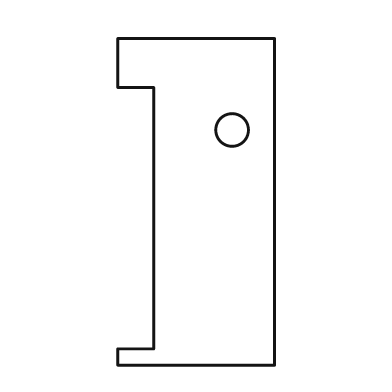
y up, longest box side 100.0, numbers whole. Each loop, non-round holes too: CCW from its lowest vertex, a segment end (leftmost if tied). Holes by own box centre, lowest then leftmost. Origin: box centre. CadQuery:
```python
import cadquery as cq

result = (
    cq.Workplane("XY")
    .moveTo(-24.0, -50.0)
    .lineTo(24.0, -50.0)
    .lineTo(24.0, 50.0)
    .lineTo(-24.0, 50.0)
    .lineTo(-24.0, 35.0)
    .lineTo(-13.0, 35.0)
    .lineTo(-13.0, -45.0)
    .lineTo(-24.0, -45.0)
    .close()
    .moveTo(11.0, 22.0)
    .circle(5.0)
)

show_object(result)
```